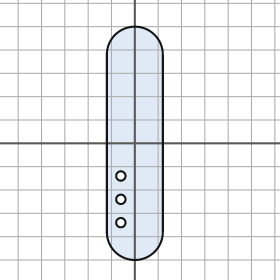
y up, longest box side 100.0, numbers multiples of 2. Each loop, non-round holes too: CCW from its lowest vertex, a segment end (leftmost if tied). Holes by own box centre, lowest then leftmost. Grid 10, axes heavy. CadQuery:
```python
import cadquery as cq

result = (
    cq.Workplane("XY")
    .moveTo(-12.0, -38.0)
    .threePointArc((0.0, -50.0), (12.0, -38.0))
    .lineTo(12.0, 38.0)
    .threePointArc((0.0, 50.0), (-12.0, 38.0))
    .close()
    .moveTo(-6.0, -34.0)
    .circle(2.0)
    .moveTo(-6.0, -24.0)
    .circle(2.0)
    .moveTo(-6.0, -14.0)
    .circle(2.0)
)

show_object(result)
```